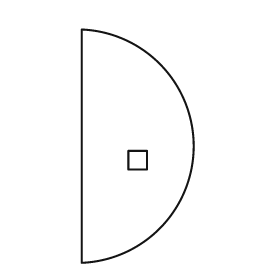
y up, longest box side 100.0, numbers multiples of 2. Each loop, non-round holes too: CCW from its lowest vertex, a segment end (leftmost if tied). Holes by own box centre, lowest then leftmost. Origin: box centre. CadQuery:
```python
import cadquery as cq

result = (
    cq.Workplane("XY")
    .moveTo(-24.0, -50.0)
    .threePointArc((24.0, 0.0), (-24.0, 50.0))
    .close()
    .moveTo(-4.0, -10.0)
    .lineTo(4.0, -10.0)
    .lineTo(4.0, -2.0)
    .lineTo(-4.0, -2.0)
    .close()
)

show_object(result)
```